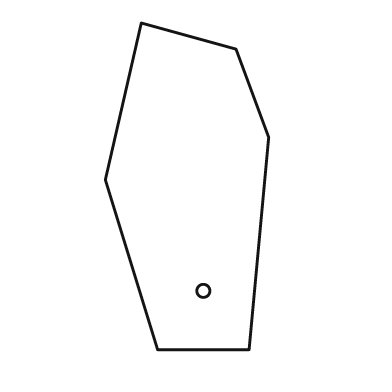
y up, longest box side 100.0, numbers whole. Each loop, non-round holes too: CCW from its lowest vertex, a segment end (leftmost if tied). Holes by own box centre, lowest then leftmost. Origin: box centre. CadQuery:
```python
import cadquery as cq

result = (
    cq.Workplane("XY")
    .moveTo(-9.0, -50.0)
    .lineTo(19.0, -50.0)
    .lineTo(25.0, 15.0)
    .lineTo(15.0, 42.0)
    .lineTo(-14.0, 50.0)
    .lineTo(-25.0, 2.0)
    .close()
    .moveTo(5.0, -32.0)
    .circle(2.0)
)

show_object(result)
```